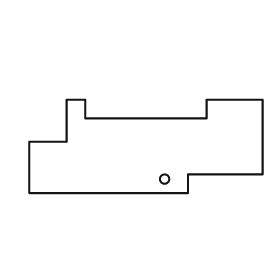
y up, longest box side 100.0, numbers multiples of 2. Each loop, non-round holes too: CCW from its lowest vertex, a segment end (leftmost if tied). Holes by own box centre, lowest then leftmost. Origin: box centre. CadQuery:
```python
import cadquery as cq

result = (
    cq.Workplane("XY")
    .moveTo(-50.0, -20.0)
    .lineTo(18.0, -20.0)
    .lineTo(18.0, -12.0)
    .lineTo(50.0, -12.0)
    .lineTo(50.0, 20.0)
    .lineTo(26.0, 20.0)
    .lineTo(26.0, 12.0)
    .lineTo(-26.0, 12.0)
    .lineTo(-26.0, 20.0)
    .lineTo(-34.0, 20.0)
    .lineTo(-34.0, 2.0)
    .lineTo(-50.0, 2.0)
    .close()
    .moveTo(8.0, -14.0)
    .circle(2.0)
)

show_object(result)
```